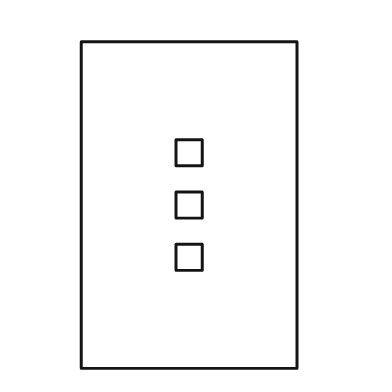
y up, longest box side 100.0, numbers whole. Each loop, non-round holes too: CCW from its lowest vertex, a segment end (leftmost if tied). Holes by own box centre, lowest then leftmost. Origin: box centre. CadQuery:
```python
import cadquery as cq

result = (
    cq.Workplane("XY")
    .moveTo(-33.0, -50.0)
    .lineTo(33.0, -50.0)
    .lineTo(33.0, 50.0)
    .lineTo(-33.0, 50.0)
    .close()
    .moveTo(-4.0, -20.0)
    .lineTo(4.0, -20.0)
    .lineTo(4.0, -12.0)
    .lineTo(-4.0, -12.0)
    .close()
    .moveTo(-4.0, -4.0)
    .lineTo(4.0, -4.0)
    .lineTo(4.0, 4.0)
    .lineTo(-4.0, 4.0)
    .close()
    .moveTo(-4.0, 12.0)
    .lineTo(4.0, 12.0)
    .lineTo(4.0, 20.0)
    .lineTo(-4.0, 20.0)
    .close()
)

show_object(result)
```